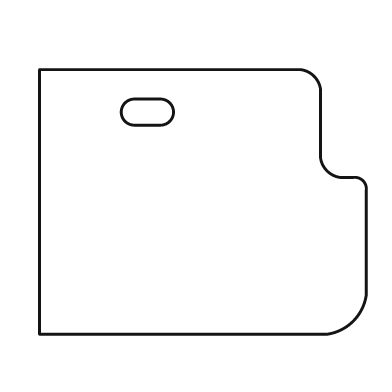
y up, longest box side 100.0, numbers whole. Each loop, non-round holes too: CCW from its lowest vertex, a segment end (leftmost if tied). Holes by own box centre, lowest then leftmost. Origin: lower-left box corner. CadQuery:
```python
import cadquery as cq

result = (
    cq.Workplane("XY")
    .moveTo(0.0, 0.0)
    .lineTo(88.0, 0.0)
    .threePointArc((96.0, 4.0), (100.0, 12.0))
    .lineTo(100.0, 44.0)
    .threePointArc((99.0, 47.0), (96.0, 48.0))
    .lineTo(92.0, 48.0)
    .threePointArc((88.0, 50.0), (86.0, 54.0))
    .lineTo(86.0, 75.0)
    .threePointArc((84.0, 79.0), (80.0, 81.0))
    .lineTo(0.0, 81.0)
    .close()
    .moveTo(29.0, 64.0)
    .lineTo(37.0, 64.0)
    .threePointArc((41.0, 68.0), (37.0, 72.0))
    .lineTo(29.0, 72.0)
    .threePointArc((25.0, 68.0), (29.0, 64.0))
    .close()
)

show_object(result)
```